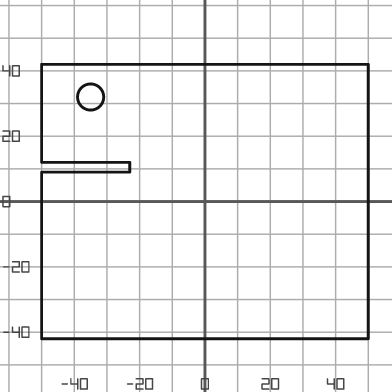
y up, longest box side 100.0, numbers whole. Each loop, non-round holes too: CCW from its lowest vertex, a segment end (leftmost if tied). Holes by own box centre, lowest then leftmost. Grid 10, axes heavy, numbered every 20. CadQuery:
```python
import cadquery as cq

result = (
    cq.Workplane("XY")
    .moveTo(-50.0, -42.0)
    .lineTo(50.0, -42.0)
    .lineTo(50.0, 42.0)
    .lineTo(-50.0, 42.0)
    .lineTo(-50.0, 12.0)
    .lineTo(-23.0, 12.0)
    .lineTo(-23.0, 9.0)
    .lineTo(-50.0, 9.0)
    .close()
    .moveTo(-35.0, 32.0)
    .circle(4.0)
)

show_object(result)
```